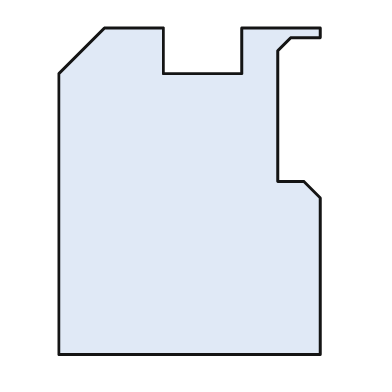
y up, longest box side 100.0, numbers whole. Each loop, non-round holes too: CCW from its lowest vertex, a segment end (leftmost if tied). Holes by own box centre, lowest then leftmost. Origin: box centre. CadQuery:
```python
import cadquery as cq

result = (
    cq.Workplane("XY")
    .moveTo(-40.0, -50.0)
    .lineTo(40.0, -50.0)
    .lineTo(40.0, -2.0)
    .lineTo(35.0, 3.0)
    .lineTo(27.0, 3.0)
    .lineTo(27.0, 43.0)
    .lineTo(31.0, 47.0)
    .lineTo(40.0, 47.0)
    .lineTo(40.0, 50.0)
    .lineTo(16.0, 50.0)
    .lineTo(16.0, 36.0)
    .lineTo(-8.0, 36.0)
    .lineTo(-8.0, 50.0)
    .lineTo(-26.0, 50.0)
    .lineTo(-40.0, 36.0)
    .close()
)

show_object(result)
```